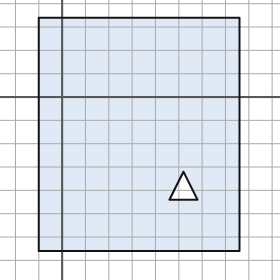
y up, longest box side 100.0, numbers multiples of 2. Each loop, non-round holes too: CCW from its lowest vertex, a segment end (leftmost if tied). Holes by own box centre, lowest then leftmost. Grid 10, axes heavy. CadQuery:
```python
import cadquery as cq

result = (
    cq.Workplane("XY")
    .moveTo(-10.0, -66.0)
    .lineTo(76.0, -66.0)
    .lineTo(76.0, 34.0)
    .lineTo(-10.0, 34.0)
    .close()
    .moveTo(46.0, -44.0)
    .lineTo(58.0, -44.0)
    .lineTo(52.0, -32.0)
    .close()
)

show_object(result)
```